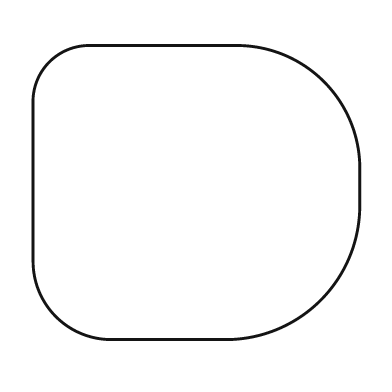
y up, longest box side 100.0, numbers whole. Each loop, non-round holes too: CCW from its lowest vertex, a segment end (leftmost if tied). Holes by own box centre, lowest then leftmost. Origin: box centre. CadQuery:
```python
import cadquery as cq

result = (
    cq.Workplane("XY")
    .moveTo(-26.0, -45.0)
    .lineTo(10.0, -45.0)
    .threePointArc((38.0, -33.0), (50.0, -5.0))
    .lineTo(50.0, 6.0)
    .threePointArc((39.0, 34.0), (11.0, 45.0))
    .lineTo(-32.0, 45.0)
    .threePointArc((-45.0, 40.0), (-50.0, 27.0))
    .lineTo(-50.0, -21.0)
    .threePointArc((-43.0, -38.0), (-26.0, -45.0))
    .close()
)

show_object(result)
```